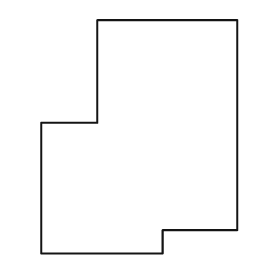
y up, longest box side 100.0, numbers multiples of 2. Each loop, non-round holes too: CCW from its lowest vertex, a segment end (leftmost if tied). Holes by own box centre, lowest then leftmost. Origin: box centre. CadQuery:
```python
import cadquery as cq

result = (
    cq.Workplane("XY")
    .moveTo(-42.0, -50.0)
    .lineTo(10.0, -50.0)
    .lineTo(10.0, -40.0)
    .lineTo(42.0, -40.0)
    .lineTo(42.0, 50.0)
    .lineTo(-18.0, 50.0)
    .lineTo(-18.0, 6.0)
    .lineTo(-42.0, 6.0)
    .close()
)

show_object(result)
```